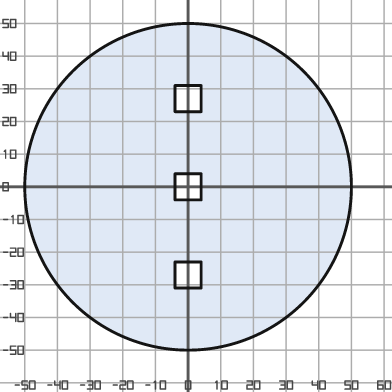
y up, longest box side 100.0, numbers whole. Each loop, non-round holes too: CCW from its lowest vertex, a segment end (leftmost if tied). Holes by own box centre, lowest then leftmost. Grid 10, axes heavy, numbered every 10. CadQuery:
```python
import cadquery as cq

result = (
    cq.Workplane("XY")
    .moveTo(0.0, 0.0)
    .circle(50.0)
    .moveTo(-4.0, -31.0)
    .lineTo(4.0, -31.0)
    .lineTo(4.0, -23.0)
    .lineTo(-4.0, -23.0)
    .close()
    .moveTo(-4.0, -4.0)
    .lineTo(4.0, -4.0)
    .lineTo(4.0, 4.0)
    .lineTo(-4.0, 4.0)
    .close()
    .moveTo(-4.0, 23.0)
    .lineTo(4.0, 23.0)
    .lineTo(4.0, 31.0)
    .lineTo(-4.0, 31.0)
    .close()
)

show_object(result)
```